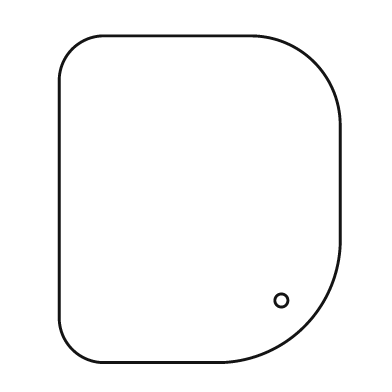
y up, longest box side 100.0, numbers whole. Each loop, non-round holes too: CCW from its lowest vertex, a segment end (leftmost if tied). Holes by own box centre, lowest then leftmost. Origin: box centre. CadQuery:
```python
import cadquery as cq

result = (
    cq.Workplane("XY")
    .moveTo(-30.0, -50.0)
    .lineTo(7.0, -50.0)
    .threePointArc((32.0, -39.0), (43.0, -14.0))
    .lineTo(43.0, 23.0)
    .threePointArc((35.0, 42.0), (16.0, 50.0))
    .lineTo(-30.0, 50.0)
    .threePointArc((-39.0, 46.0), (-43.0, 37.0))
    .lineTo(-43.0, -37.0)
    .threePointArc((-39.0, -46.0), (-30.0, -50.0))
    .close()
    .moveTo(25.0, -31.0)
    .circle(2.0)
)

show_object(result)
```